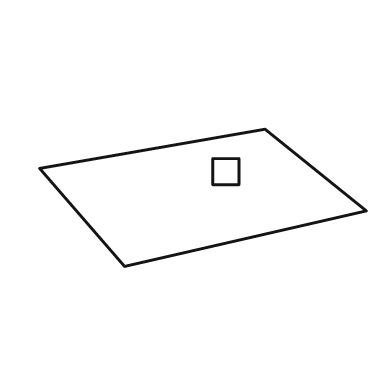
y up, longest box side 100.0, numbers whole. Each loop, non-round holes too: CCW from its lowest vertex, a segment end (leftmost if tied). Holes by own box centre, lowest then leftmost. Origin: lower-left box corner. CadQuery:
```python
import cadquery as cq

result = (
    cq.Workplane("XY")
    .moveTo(26.0, 0.0)
    .lineTo(100.0, 17.0)
    .lineTo(69.0, 42.0)
    .lineTo(0.0, 30.0)
    .close()
    .moveTo(53.0, 25.0)
    .lineTo(61.0, 25.0)
    .lineTo(61.0, 33.0)
    .lineTo(53.0, 33.0)
    .close()
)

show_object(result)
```